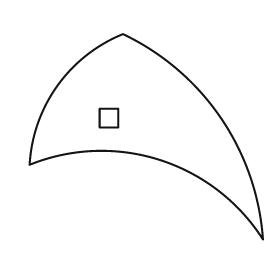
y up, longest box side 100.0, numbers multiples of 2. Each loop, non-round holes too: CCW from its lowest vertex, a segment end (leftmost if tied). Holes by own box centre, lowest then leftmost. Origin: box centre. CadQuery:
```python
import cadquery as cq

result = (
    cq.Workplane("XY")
    .moveTo(50.0, -44.0)
    .threePointArc((32.0, 8.0), (-10.0, 44.0))
    .threePointArc((-38.0, 22.0), (-50.0, -12.0))
    .threePointArc((6.0, -10.0), (50.0, -44.0))
    .close()
    .moveTo(-20.0, 4.0)
    .lineTo(-12.0, 4.0)
    .lineTo(-12.0, 12.0)
    .lineTo(-20.0, 12.0)
    .close()
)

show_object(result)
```